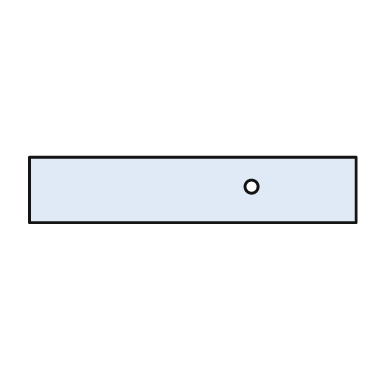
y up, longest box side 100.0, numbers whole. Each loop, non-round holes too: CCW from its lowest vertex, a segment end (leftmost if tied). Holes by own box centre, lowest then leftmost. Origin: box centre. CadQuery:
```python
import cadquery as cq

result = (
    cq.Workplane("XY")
    .moveTo(-50.0, -10.0)
    .lineTo(50.0, -10.0)
    .lineTo(50.0, 10.0)
    .lineTo(-50.0, 10.0)
    .close()
    .moveTo(18.0, 1.0)
    .circle(2.0)
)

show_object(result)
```